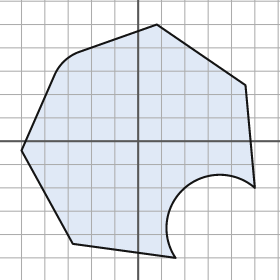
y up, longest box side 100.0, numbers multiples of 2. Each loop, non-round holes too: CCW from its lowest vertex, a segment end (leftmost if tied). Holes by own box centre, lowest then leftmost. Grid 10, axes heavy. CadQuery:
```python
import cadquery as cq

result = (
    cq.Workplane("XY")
    .moveTo(16.0, -50.0)
    .threePointArc((20.0, -20.0), (50.0, -20.0))
    .lineTo(46.0, 24.0)
    .lineTo(8.0, 50.0)
    .lineTo(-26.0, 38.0)
    .threePointArc((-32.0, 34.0), (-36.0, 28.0))
    .lineTo(-50.0, -4.0)
    .lineTo(-28.0, -44.0)
    .close()
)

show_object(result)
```